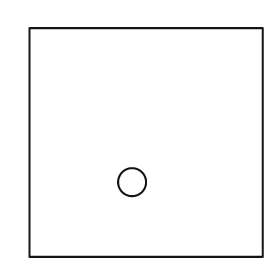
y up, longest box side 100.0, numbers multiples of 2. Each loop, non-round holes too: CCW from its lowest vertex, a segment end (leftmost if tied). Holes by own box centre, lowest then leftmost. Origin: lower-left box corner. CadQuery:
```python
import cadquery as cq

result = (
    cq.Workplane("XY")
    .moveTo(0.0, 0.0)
    .lineTo(100.0, 0.0)
    .lineTo(100.0, 98.0)
    .lineTo(0.0, 98.0)
    .close()
    .moveTo(44.0, 32.0)
    .circle(6.0)
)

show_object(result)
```